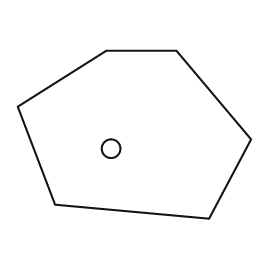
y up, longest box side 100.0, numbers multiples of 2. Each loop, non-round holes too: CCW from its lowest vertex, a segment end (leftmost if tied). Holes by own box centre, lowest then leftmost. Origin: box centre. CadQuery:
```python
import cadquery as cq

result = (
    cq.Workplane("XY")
    .moveTo(32.0, -36.0)
    .lineTo(50.0, -2.0)
    .lineTo(18.0, 36.0)
    .lineTo(-12.0, 36.0)
    .lineTo(-50.0, 12.0)
    .lineTo(-34.0, -30.0)
    .close()
    .moveTo(-10.0, -6.0)
    .circle(4.0)
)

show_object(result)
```